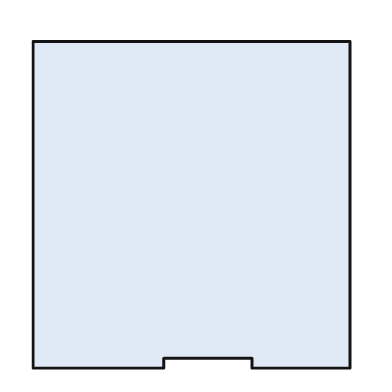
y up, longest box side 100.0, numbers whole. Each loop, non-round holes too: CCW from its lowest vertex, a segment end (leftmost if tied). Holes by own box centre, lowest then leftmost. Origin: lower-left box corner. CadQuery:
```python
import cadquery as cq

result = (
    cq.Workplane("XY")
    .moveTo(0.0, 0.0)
    .lineTo(40.0, 0.0)
    .lineTo(40.0, 3.0)
    .lineTo(67.0, 3.0)
    .lineTo(67.0, 0.0)
    .lineTo(97.0, 0.0)
    .lineTo(97.0, 100.0)
    .lineTo(0.0, 100.0)
    .close()
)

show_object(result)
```